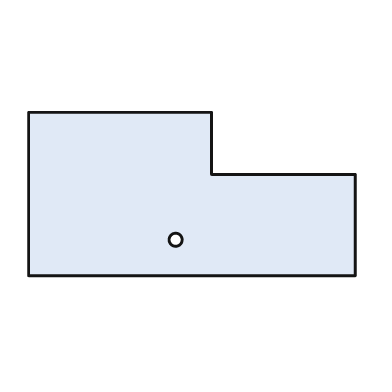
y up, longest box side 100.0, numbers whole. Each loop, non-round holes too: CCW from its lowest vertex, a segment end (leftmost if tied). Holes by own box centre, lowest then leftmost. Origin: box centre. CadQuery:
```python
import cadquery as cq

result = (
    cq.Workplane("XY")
    .moveTo(-50.0, -25.0)
    .lineTo(50.0, -25.0)
    .lineTo(50.0, 6.0)
    .lineTo(6.0, 6.0)
    .lineTo(6.0, 25.0)
    .lineTo(-50.0, 25.0)
    .close()
    .moveTo(-5.0, -14.0)
    .circle(2.0)
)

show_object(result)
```